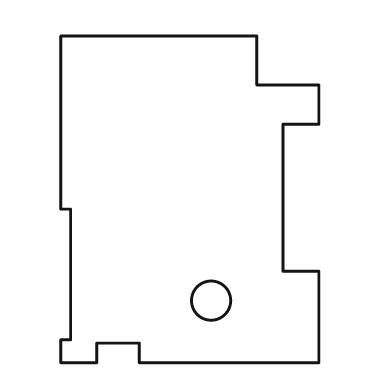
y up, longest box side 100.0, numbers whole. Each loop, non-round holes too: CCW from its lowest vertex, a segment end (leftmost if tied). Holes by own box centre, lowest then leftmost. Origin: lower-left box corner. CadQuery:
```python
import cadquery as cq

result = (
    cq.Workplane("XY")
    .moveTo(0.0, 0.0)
    .lineTo(11.0, 0.0)
    .lineTo(11.0, 6.0)
    .lineTo(24.0, 6.0)
    .lineTo(24.0, 0.0)
    .lineTo(79.0, 0.0)
    .lineTo(79.0, 28.0)
    .lineTo(68.0, 28.0)
    .lineTo(68.0, 73.0)
    .lineTo(79.0, 73.0)
    .lineTo(79.0, 85.0)
    .lineTo(60.0, 85.0)
    .lineTo(60.0, 100.0)
    .lineTo(0.0, 100.0)
    .lineTo(0.0, 47.0)
    .lineTo(3.0, 47.0)
    .lineTo(3.0, 7.0)
    .lineTo(0.0, 7.0)
    .close()
    .moveTo(46.0, 19.0)
    .circle(6.0)
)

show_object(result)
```